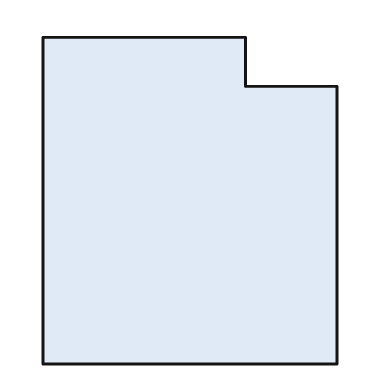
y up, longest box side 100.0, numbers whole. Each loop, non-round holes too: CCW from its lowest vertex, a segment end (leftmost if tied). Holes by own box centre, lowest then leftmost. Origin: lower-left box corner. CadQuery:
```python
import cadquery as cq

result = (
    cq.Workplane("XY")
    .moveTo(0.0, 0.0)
    .lineTo(90.0, 0.0)
    .lineTo(90.0, 85.0)
    .lineTo(62.0, 85.0)
    .lineTo(62.0, 100.0)
    .lineTo(0.0, 100.0)
    .close()
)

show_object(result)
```